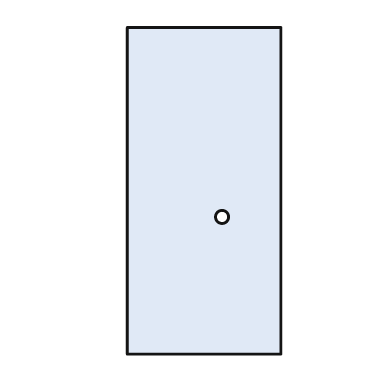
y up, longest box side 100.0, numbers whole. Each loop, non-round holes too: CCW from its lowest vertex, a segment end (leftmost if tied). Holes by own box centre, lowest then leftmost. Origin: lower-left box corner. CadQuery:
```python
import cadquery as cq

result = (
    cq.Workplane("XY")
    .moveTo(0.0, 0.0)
    .lineTo(47.0, 0.0)
    .lineTo(47.0, 100.0)
    .lineTo(0.0, 100.0)
    .close()
    .moveTo(29.0, 42.0)
    .circle(2.0)
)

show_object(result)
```